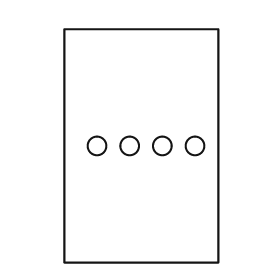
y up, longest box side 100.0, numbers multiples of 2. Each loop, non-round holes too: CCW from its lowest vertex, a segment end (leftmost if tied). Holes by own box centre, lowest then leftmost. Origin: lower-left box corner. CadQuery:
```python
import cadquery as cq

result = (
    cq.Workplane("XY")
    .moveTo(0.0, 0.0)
    .lineTo(66.0, 0.0)
    .lineTo(66.0, 100.0)
    .lineTo(0.0, 100.0)
    .close()
    .moveTo(14.0, 50.0)
    .circle(4.0)
    .moveTo(28.0, 50.0)
    .circle(4.0)
    .moveTo(42.0, 50.0)
    .circle(4.0)
    .moveTo(56.0, 50.0)
    .circle(4.0)
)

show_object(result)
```